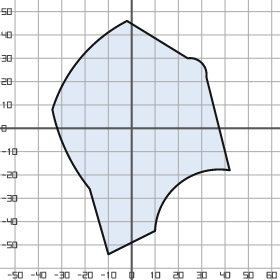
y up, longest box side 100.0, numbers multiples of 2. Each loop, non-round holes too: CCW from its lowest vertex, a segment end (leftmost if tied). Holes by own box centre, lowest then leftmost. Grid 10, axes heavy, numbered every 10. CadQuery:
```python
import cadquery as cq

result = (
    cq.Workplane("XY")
    .moveTo(-10.0, -54.0)
    .lineTo(10.0, -44.0)
    .threePointArc((20.0, -24.0), (42.0, -18.0))
    .lineTo(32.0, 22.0)
    .threePointArc((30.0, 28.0), (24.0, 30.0))
    .lineTo(-2.0, 46.0)
    .threePointArc((-22.0, 30.0), (-34.0, 8.0))
    .threePointArc((-28.0, -10.0), (-18.0, -26.0))
    .close()
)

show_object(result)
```